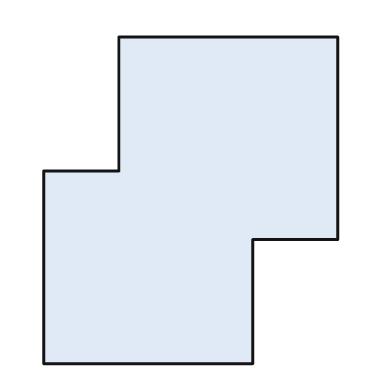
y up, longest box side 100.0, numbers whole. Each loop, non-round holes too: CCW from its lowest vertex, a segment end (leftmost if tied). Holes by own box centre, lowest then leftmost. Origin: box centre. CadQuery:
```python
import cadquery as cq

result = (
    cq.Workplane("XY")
    .moveTo(-45.0, -50.0)
    .lineTo(19.0, -50.0)
    .lineTo(19.0, -12.0)
    .lineTo(45.0, -12.0)
    .lineTo(45.0, 50.0)
    .lineTo(-22.0, 50.0)
    .lineTo(-22.0, 9.0)
    .lineTo(-45.0, 9.0)
    .close()
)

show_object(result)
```